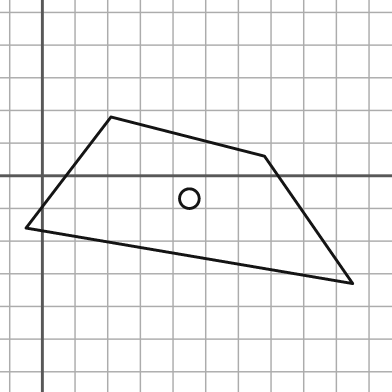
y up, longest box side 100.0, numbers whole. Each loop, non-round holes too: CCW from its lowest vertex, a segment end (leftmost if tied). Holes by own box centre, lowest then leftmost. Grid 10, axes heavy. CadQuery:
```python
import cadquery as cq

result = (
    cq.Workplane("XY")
    .moveTo(95.0, -33.0)
    .lineTo(68.0, 6.0)
    .lineTo(21.0, 18.0)
    .lineTo(-5.0, -16.0)
    .close()
    .moveTo(45.0, -7.0)
    .circle(3.0)
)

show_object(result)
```